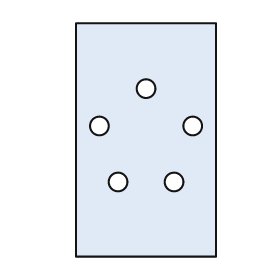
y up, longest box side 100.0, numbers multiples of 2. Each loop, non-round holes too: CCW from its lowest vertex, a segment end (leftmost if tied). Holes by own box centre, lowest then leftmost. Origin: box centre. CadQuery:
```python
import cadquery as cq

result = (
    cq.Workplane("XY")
    .moveTo(-30.0, -50.0)
    .lineTo(30.0, -50.0)
    .lineTo(30.0, 50.0)
    .lineTo(-30.0, 50.0)
    .close()
    .moveTo(-12.0, -18.0)
    .circle(4.0)
    .moveTo(12.0, -18.0)
    .circle(4.0)
    .moveTo(-20.0, 6.0)
    .circle(4.0)
    .moveTo(20.0, 6.0)
    .circle(4.0)
    .moveTo(0.0, 22.0)
    .circle(4.0)
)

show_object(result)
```